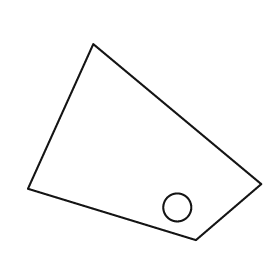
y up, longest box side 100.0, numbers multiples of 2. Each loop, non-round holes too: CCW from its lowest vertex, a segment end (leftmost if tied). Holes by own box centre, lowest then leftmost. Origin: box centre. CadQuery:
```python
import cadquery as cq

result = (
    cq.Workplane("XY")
    .moveTo(22.0, -42.0)
    .lineTo(50.0, -18.0)
    .lineTo(-22.0, 42.0)
    .lineTo(-50.0, -20.0)
    .close()
    .moveTo(14.0, -28.0)
    .circle(6.0)
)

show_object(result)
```